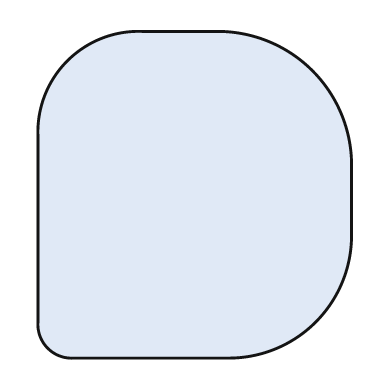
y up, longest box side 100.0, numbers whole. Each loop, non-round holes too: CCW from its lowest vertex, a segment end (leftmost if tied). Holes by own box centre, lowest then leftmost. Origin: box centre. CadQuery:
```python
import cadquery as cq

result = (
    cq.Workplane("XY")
    .moveTo(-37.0, -50.0)
    .lineTo(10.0, -50.0)
    .threePointArc((37.0, -39.0), (48.0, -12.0))
    .lineTo(48.0, 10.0)
    .threePointArc((36.0, 38.0), (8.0, 50.0))
    .lineTo(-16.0, 50.0)
    .threePointArc((-39.0, 41.0), (-48.0, 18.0))
    .lineTo(-48.0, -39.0)
    .threePointArc((-45.0, -47.0), (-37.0, -50.0))
    .close()
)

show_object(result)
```